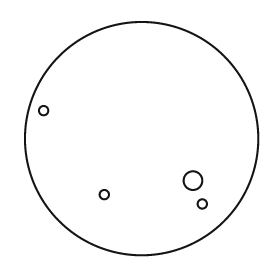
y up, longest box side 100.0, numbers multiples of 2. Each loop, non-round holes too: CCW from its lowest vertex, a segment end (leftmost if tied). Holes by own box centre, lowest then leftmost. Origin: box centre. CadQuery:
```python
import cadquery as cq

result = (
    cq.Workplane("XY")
    .moveTo(0.0, 0.0)
    .circle(50.0)
    .moveTo(26.0, -28.0)
    .circle(2.0)
    .moveTo(-16.0, -24.0)
    .circle(2.0)
    .moveTo(22.0, -18.0)
    .circle(4.0)
    .moveTo(-42.0, 12.0)
    .circle(2.0)
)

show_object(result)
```